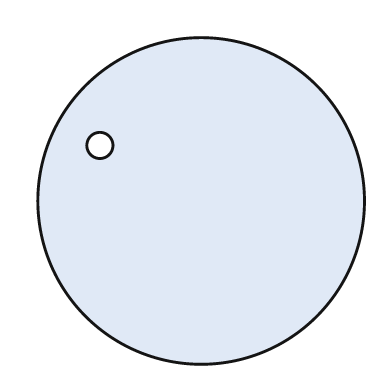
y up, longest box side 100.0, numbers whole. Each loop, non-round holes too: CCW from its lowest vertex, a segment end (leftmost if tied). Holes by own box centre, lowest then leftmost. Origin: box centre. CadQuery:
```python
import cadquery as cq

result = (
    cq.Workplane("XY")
    .moveTo(0.0, 0.0)
    .circle(50.0)
    .moveTo(-31.0, 17.0)
    .circle(4.0)
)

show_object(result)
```